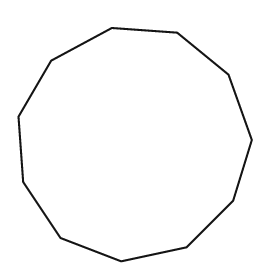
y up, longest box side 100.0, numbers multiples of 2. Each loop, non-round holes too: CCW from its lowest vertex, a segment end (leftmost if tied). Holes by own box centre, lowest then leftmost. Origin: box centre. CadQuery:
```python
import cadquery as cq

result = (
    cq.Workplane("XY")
    .moveTo(-6.0, -50.0)
    .lineTo(22.0, -44.0)
    .lineTo(42.0, -24.0)
    .lineTo(50.0, 2.0)
    .lineTo(40.0, 30.0)
    .lineTo(18.0, 48.0)
    .lineTo(-10.0, 50.0)
    .lineTo(-36.0, 36.0)
    .lineTo(-50.0, 12.0)
    .lineTo(-48.0, -16.0)
    .lineTo(-32.0, -40.0)
    .close()
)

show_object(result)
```